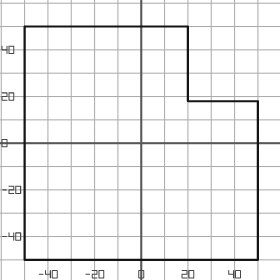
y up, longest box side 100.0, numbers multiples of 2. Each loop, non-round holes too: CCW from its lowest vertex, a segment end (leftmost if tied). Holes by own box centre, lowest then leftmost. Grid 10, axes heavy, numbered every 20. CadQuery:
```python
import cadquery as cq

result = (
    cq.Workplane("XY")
    .moveTo(-50.0, -50.0)
    .lineTo(50.0, -50.0)
    .lineTo(50.0, 18.0)
    .lineTo(20.0, 18.0)
    .lineTo(20.0, 50.0)
    .lineTo(-50.0, 50.0)
    .close()
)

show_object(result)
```